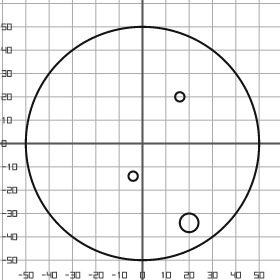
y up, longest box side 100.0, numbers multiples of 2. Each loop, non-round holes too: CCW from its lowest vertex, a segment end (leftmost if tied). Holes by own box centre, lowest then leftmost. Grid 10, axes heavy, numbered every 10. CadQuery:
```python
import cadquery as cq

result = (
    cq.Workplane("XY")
    .moveTo(0.0, 0.0)
    .circle(50.0)
    .moveTo(20.0, -34.0)
    .circle(4.0)
    .moveTo(-4.0, -14.0)
    .circle(2.0)
    .moveTo(16.0, 20.0)
    .circle(2.0)
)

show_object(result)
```